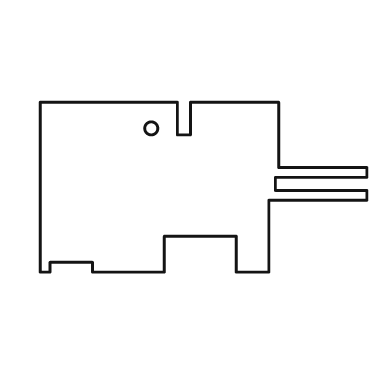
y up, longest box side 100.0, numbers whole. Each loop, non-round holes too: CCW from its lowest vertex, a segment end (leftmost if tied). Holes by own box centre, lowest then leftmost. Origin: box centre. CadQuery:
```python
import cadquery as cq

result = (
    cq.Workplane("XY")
    .moveTo(-50.0, -26.0)
    .lineTo(-47.0, -26.0)
    .lineTo(-47.0, -23.0)
    .lineTo(-34.0, -23.0)
    .lineTo(-34.0, -26.0)
    .lineTo(-12.0, -26.0)
    .lineTo(-12.0, -15.0)
    .lineTo(10.0, -15.0)
    .lineTo(10.0, -26.0)
    .lineTo(20.0, -26.0)
    .lineTo(20.0, -4.0)
    .lineTo(50.0, -4.0)
    .lineTo(50.0, -1.0)
    .lineTo(22.0, -1.0)
    .lineTo(22.0, 3.0)
    .lineTo(50.0, 3.0)
    .lineTo(50.0, 6.0)
    .lineTo(23.0, 6.0)
    .lineTo(23.0, 26.0)
    .lineTo(-4.0, 26.0)
    .lineTo(-4.0, 16.0)
    .lineTo(-8.0, 16.0)
    .lineTo(-8.0, 26.0)
    .lineTo(-50.0, 26.0)
    .close()
    .moveTo(-16.0, 18.0)
    .circle(2.0)
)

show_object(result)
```